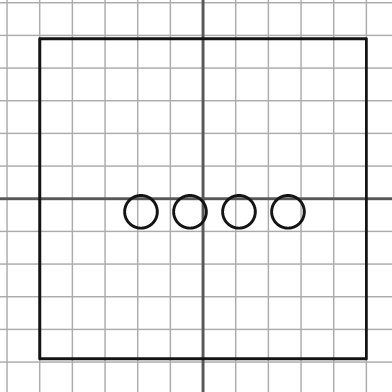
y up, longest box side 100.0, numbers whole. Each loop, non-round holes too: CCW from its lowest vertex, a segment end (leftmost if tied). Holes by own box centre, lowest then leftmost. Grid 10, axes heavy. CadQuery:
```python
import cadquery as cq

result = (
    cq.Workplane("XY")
    .moveTo(-50.0, -49.0)
    .lineTo(50.0, -49.0)
    .lineTo(50.0, 49.0)
    .lineTo(-50.0, 49.0)
    .close()
    .moveTo(-19.0, -4.0)
    .circle(5.0)
    .moveTo(-4.0, -4.0)
    .circle(5.0)
    .moveTo(11.0, -4.0)
    .circle(5.0)
    .moveTo(26.0, -4.0)
    .circle(5.0)
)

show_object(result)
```